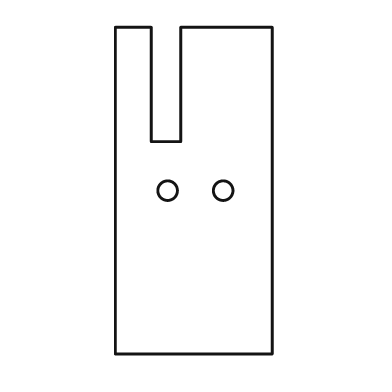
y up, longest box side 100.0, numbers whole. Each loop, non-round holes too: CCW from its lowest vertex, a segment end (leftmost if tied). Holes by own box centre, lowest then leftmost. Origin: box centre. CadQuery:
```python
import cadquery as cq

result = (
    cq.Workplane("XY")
    .moveTo(-24.0, -50.0)
    .lineTo(24.0, -50.0)
    .lineTo(24.0, 50.0)
    .lineTo(-4.0, 50.0)
    .lineTo(-4.0, 15.0)
    .lineTo(-13.0, 15.0)
    .lineTo(-13.0, 50.0)
    .lineTo(-24.0, 50.0)
    .close()
    .moveTo(-8.0, 0.0)
    .circle(3.0)
    .moveTo(9.0, 0.0)
    .circle(3.0)
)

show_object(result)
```